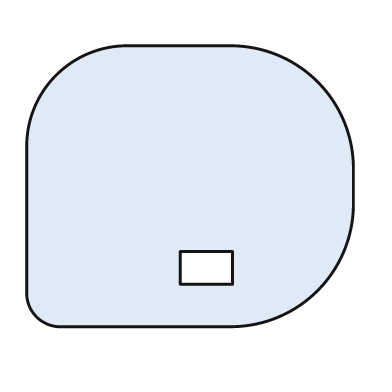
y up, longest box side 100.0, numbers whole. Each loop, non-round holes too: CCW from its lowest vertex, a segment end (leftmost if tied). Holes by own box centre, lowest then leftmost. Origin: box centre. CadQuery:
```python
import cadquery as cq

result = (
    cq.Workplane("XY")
    .moveTo(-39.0, -43.0)
    .lineTo(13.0, -43.0)
    .threePointArc((39.0, -32.0), (50.0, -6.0))
    .lineTo(50.0, 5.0)
    .threePointArc((39.0, 32.0), (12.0, 43.0))
    .lineTo(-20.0, 43.0)
    .threePointArc((-41.0, 34.0), (-50.0, 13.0))
    .lineTo(-50.0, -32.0)
    .threePointArc((-47.0, -40.0), (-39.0, -43.0))
    .close()
    .moveTo(-3.0, -30.0)
    .lineTo(13.0, -30.0)
    .lineTo(13.0, -20.0)
    .lineTo(-3.0, -20.0)
    .close()
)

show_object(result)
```